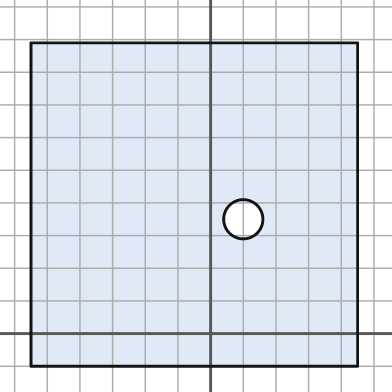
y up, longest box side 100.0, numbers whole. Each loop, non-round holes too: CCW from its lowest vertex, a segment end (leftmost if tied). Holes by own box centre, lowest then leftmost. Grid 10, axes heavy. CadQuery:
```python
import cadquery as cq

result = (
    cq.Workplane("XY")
    .moveTo(-55.0, -10.0)
    .lineTo(45.0, -10.0)
    .lineTo(45.0, 89.0)
    .lineTo(-55.0, 89.0)
    .close()
    .moveTo(10.0, 35.0)
    .circle(6.0)
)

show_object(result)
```